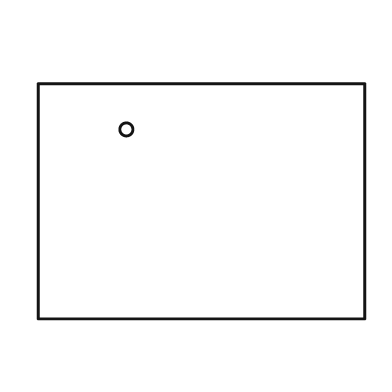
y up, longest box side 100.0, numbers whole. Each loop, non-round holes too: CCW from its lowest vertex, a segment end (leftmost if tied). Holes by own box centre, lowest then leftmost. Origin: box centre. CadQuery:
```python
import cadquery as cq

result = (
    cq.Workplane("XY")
    .moveTo(-50.0, -36.0)
    .lineTo(50.0, -36.0)
    .lineTo(50.0, 36.0)
    .lineTo(-50.0, 36.0)
    .close()
    .moveTo(-23.0, 22.0)
    .circle(2.0)
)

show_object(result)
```